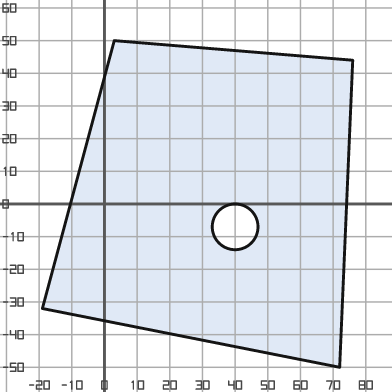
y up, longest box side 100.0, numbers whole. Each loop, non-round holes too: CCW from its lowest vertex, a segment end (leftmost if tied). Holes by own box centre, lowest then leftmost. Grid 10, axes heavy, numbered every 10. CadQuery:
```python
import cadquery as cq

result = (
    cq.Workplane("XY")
    .moveTo(72.0, -50.0)
    .lineTo(76.0, 44.0)
    .lineTo(3.0, 50.0)
    .lineTo(-19.0, -32.0)
    .close()
    .moveTo(40.0, -7.0)
    .circle(7.0)
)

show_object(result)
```